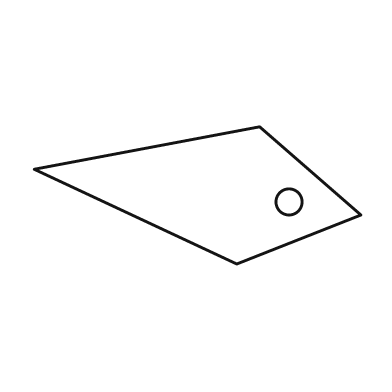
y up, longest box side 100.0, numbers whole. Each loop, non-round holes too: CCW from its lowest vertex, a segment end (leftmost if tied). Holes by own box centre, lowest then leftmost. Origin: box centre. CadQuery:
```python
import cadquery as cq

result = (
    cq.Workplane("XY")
    .moveTo(12.0, -21.0)
    .lineTo(50.0, -6.0)
    .lineTo(19.0, 21.0)
    .lineTo(-50.0, 8.0)
    .close()
    .moveTo(28.0, -2.0)
    .circle(4.0)
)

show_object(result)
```